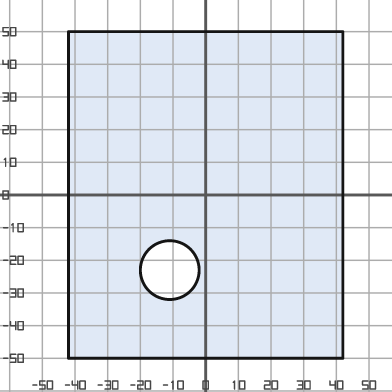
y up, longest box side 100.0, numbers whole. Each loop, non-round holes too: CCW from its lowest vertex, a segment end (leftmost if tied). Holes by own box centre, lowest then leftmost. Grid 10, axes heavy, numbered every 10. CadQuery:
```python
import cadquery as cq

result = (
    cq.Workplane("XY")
    .moveTo(-42.0, -50.0)
    .lineTo(42.0, -50.0)
    .lineTo(42.0, 50.0)
    .lineTo(-42.0, 50.0)
    .close()
    .moveTo(-11.0, -23.0)
    .circle(9.0)
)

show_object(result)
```